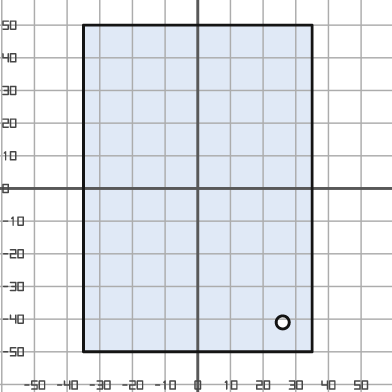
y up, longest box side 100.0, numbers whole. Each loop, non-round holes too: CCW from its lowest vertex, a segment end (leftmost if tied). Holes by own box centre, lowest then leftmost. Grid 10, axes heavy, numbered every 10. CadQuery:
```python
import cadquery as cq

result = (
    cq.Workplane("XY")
    .moveTo(-35.0, -50.0)
    .lineTo(35.0, -50.0)
    .lineTo(35.0, 50.0)
    .lineTo(-35.0, 50.0)
    .close()
    .moveTo(26.0, -41.0)
    .circle(2.0)
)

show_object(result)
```